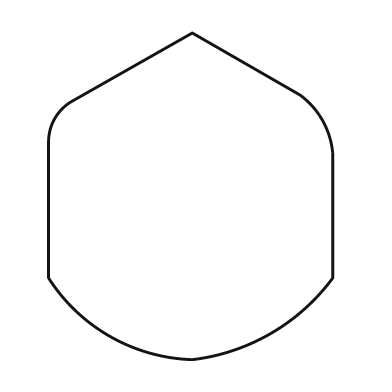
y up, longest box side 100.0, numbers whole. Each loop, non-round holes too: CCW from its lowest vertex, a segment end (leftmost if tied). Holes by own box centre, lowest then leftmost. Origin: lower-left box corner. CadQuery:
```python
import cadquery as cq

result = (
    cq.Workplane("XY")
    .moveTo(44.0, 0.0)
    .threePointArc((68.0, 8.0), (87.0, 25.0))
    .lineTo(87.0, 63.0)
    .threePointArc((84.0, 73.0), (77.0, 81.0))
    .lineTo(44.0, 100.0)
    .lineTo(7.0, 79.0)
    .threePointArc((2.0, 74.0), (0.0, 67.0))
    .lineTo(0.0, 25.0)
    .threePointArc((19.0, 7.0), (44.0, 0.0))
    .close()
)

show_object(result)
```